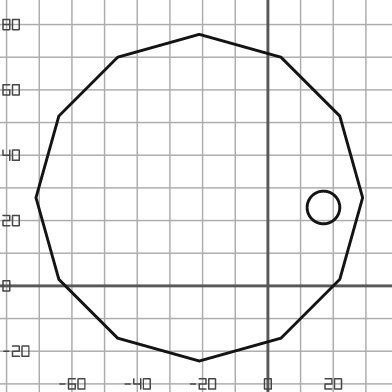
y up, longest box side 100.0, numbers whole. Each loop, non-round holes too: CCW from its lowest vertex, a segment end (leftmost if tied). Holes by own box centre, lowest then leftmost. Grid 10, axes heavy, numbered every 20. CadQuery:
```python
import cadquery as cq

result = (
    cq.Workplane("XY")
    .moveTo(-21.0, -23.0)
    .lineTo(4.0, -16.0)
    .lineTo(22.0, 2.0)
    .lineTo(29.0, 27.0)
    .lineTo(22.0, 52.0)
    .lineTo(4.0, 70.0)
    .lineTo(-21.0, 77.0)
    .lineTo(-46.0, 70.0)
    .lineTo(-64.0, 52.0)
    .lineTo(-71.0, 27.0)
    .lineTo(-64.0, 2.0)
    .lineTo(-46.0, -16.0)
    .close()
    .moveTo(17.0, 24.0)
    .circle(5.0)
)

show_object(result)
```